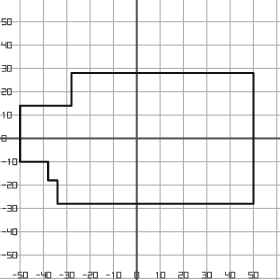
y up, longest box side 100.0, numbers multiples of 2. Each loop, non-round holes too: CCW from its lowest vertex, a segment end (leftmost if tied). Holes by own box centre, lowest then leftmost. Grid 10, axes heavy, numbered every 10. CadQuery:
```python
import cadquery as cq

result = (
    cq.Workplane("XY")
    .moveTo(-34.0, -28.0)
    .lineTo(50.0, -28.0)
    .lineTo(50.0, 28.0)
    .lineTo(-28.0, 28.0)
    .lineTo(-28.0, 14.0)
    .lineTo(-50.0, 14.0)
    .lineTo(-50.0, -10.0)
    .lineTo(-38.0, -10.0)
    .lineTo(-38.0, -18.0)
    .lineTo(-34.0, -18.0)
    .close()
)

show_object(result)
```